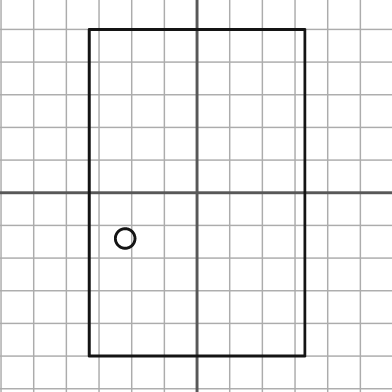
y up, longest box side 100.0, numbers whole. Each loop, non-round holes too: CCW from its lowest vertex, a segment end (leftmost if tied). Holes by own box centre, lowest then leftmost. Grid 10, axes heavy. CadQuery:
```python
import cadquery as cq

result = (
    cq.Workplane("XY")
    .moveTo(-33.0, -50.0)
    .lineTo(33.0, -50.0)
    .lineTo(33.0, 50.0)
    .lineTo(-33.0, 50.0)
    .close()
    .moveTo(-22.0, -14.0)
    .circle(3.0)
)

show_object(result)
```